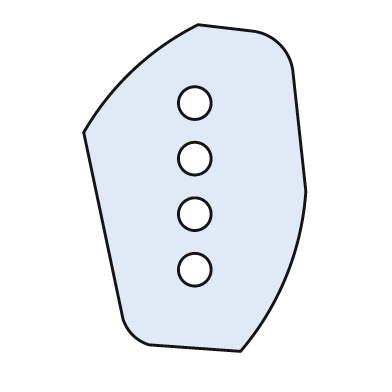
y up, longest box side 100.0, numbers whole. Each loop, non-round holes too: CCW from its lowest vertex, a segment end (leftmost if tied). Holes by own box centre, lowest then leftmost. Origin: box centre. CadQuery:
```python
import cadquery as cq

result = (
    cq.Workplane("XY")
    .moveTo(14.0, -50.0)
    .threePointArc((28.0, -27.0), (34.0, -1.0))
    .lineTo(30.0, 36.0)
    .threePointArc((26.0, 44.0), (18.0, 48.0))
    .lineTo(1.0, 50.0)
    .threePointArc((-19.0, 36.0), (-34.0, 17.0))
    .lineTo(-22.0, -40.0)
    .threePointArc((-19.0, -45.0), (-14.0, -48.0))
    .close()
    .moveTo(0.0, -25.0)
    .circle(5.0)
    .moveTo(0.0, -8.0)
    .circle(5.0)
    .moveTo(0.0, 9.0)
    .circle(5.0)
    .moveTo(0.0, 26.0)
    .circle(5.0)
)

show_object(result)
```